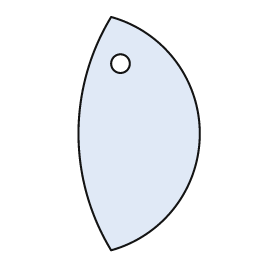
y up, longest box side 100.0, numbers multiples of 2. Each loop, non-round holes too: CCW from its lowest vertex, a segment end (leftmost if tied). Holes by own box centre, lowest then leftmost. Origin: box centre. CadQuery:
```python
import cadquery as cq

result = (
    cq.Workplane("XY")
    .moveTo(-12.0, -50.0)
    .threePointArc((26.0, 0.0), (-12.0, 50.0))
    .threePointArc((-26.0, 0.0), (-12.0, -50.0))
    .close()
    .moveTo(-8.0, 30.0)
    .circle(4.0)
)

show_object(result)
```